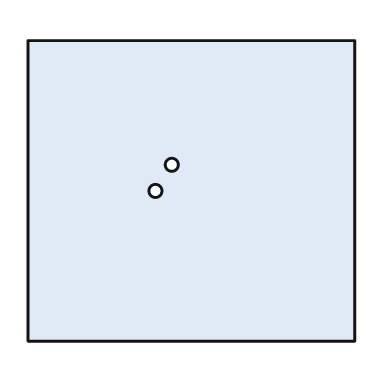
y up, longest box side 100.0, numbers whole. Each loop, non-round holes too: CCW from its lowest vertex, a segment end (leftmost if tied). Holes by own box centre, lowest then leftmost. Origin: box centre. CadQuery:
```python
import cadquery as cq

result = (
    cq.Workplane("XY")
    .moveTo(-50.0, -46.0)
    .lineTo(50.0, -46.0)
    .lineTo(50.0, 46.0)
    .lineTo(-50.0, 46.0)
    .close()
    .moveTo(-11.0, 0.0)
    .circle(2.0)
    .moveTo(-6.0, 8.0)
    .circle(2.0)
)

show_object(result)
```